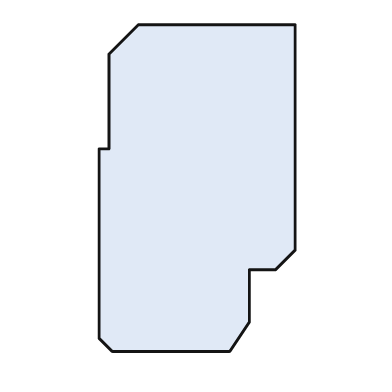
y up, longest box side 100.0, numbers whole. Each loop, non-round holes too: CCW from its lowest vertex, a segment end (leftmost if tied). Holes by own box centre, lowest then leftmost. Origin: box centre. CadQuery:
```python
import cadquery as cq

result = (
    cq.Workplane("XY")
    .moveTo(-26.0, -50.0)
    .lineTo(10.0, -50.0)
    .lineTo(16.0, -41.0)
    .lineTo(16.0, -25.0)
    .lineTo(24.0, -25.0)
    .lineTo(30.0, -19.0)
    .lineTo(30.0, 50.0)
    .lineTo(-18.0, 50.0)
    .lineTo(-27.0, 41.0)
    .lineTo(-27.0, 12.0)
    .lineTo(-30.0, 12.0)
    .lineTo(-30.0, -46.0)
    .close()
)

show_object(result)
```